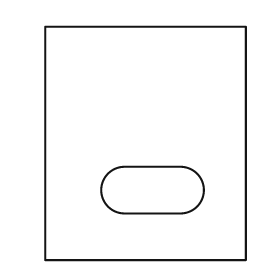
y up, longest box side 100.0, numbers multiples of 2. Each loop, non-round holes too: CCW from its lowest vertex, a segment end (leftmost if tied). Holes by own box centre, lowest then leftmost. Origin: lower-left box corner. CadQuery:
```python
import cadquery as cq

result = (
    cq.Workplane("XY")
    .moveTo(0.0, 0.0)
    .lineTo(86.0, 0.0)
    .lineTo(86.0, 100.0)
    .lineTo(0.0, 100.0)
    .close()
    .moveTo(34.0, 20.0)
    .lineTo(58.0, 20.0)
    .threePointArc((68.0, 30.0), (58.0, 40.0))
    .lineTo(34.0, 40.0)
    .threePointArc((24.0, 30.0), (34.0, 20.0))
    .close()
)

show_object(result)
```